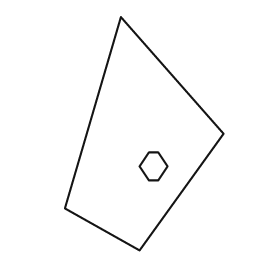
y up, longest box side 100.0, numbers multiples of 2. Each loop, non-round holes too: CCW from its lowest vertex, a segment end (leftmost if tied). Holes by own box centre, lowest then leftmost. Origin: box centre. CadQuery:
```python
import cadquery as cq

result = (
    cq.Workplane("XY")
    .moveTo(-2.0, -50.0)
    .lineTo(34.0, 0.0)
    .lineTo(-10.0, 50.0)
    .lineTo(-34.0, -32.0)
    .close()
    .moveTo(2.0, -20.0)
    .lineTo(6.0, -20.0)
    .lineTo(10.0, -14.0)
    .lineTo(6.0, -8.0)
    .lineTo(2.0, -8.0)
    .lineTo(-2.0, -14.0)
    .close()
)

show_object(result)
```